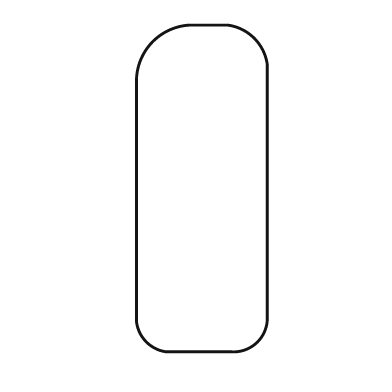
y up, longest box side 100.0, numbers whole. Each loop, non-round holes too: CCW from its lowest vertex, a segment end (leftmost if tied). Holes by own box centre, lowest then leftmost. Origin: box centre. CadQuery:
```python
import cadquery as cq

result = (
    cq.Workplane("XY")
    .moveTo(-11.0, -50.0)
    .lineTo(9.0, -50.0)
    .threePointArc((17.0, -47.0), (20.0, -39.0))
    .lineTo(20.0, 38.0)
    .threePointArc((16.0, 46.0), (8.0, 50.0))
    .lineTo(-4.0, 50.0)
    .threePointArc((-15.0, 45.0), (-20.0, 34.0))
    .lineTo(-20.0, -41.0)
    .threePointArc((-17.0, -47.0), (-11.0, -50.0))
    .close()
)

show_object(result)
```